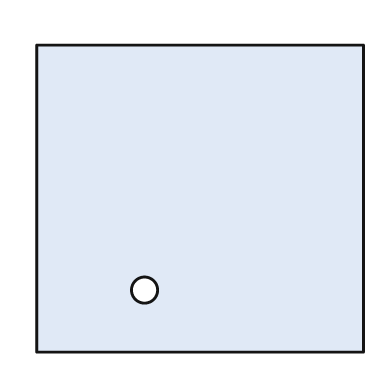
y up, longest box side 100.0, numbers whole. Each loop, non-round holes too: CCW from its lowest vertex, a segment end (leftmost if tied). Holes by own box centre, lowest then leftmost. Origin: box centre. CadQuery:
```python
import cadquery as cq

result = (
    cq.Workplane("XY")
    .moveTo(-50.0, -47.0)
    .lineTo(50.0, -47.0)
    .lineTo(50.0, 47.0)
    .lineTo(-50.0, 47.0)
    .close()
    .moveTo(-17.0, -28.0)
    .circle(4.0)
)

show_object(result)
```